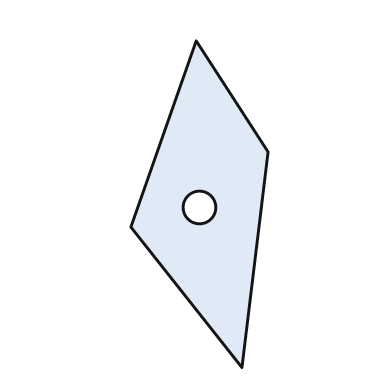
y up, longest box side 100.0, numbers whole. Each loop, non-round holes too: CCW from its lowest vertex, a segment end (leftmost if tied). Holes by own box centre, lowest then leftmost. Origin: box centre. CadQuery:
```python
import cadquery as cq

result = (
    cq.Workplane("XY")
    .moveTo(13.0, -50.0)
    .lineTo(21.0, 16.0)
    .lineTo(-1.0, 50.0)
    .lineTo(-21.0, -7.0)
    .close()
    .moveTo(0.0, -1.0)
    .circle(5.0)
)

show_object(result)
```